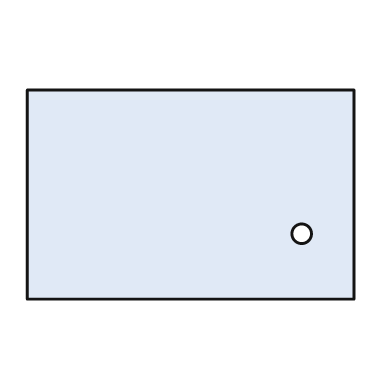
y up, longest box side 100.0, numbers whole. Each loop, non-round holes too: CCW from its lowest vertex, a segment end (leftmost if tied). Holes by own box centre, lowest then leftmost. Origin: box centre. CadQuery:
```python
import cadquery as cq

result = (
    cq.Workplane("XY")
    .moveTo(-50.0, -32.0)
    .lineTo(50.0, -32.0)
    .lineTo(50.0, 32.0)
    .lineTo(-50.0, 32.0)
    .close()
    .moveTo(34.0, -12.0)
    .circle(3.0)
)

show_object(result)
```